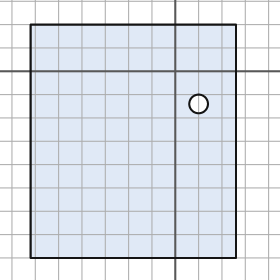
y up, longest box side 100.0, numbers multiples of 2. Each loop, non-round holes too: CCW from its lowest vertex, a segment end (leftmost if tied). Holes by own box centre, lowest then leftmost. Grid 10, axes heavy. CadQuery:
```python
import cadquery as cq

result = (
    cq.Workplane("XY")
    .moveTo(-62.0, -80.0)
    .lineTo(26.0, -80.0)
    .lineTo(26.0, 20.0)
    .lineTo(-62.0, 20.0)
    .close()
    .moveTo(10.0, -14.0)
    .circle(4.0)
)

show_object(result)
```